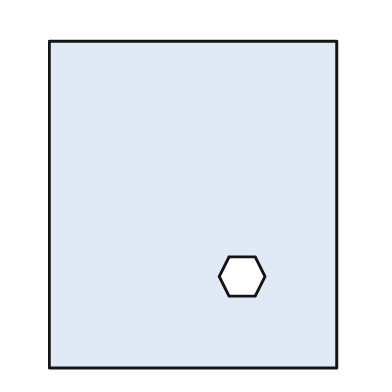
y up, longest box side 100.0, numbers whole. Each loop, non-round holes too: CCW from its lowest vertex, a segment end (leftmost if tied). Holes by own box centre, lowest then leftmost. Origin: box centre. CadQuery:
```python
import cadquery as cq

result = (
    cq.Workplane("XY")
    .moveTo(-44.0, -50.0)
    .lineTo(44.0, -50.0)
    .lineTo(44.0, 50.0)
    .lineTo(-44.0, 50.0)
    .close()
    .moveTo(11.0, -28.0)
    .lineTo(19.0, -28.0)
    .lineTo(22.0, -22.0)
    .lineTo(19.0, -16.0)
    .lineTo(11.0, -16.0)
    .lineTo(8.0, -22.0)
    .close()
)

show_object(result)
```